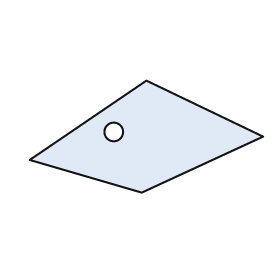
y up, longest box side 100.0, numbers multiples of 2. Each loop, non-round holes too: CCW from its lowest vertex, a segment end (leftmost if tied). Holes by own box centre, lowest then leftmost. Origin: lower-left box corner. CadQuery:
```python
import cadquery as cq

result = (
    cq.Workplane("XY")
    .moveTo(48.0, 0.0)
    .lineTo(100.0, 24.0)
    .lineTo(50.0, 48.0)
    .lineTo(0.0, 14.0)
    .close()
    .moveTo(36.0, 26.0)
    .circle(4.0)
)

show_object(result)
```